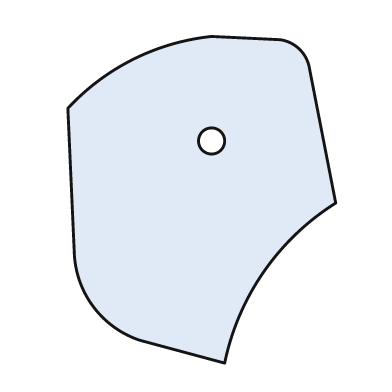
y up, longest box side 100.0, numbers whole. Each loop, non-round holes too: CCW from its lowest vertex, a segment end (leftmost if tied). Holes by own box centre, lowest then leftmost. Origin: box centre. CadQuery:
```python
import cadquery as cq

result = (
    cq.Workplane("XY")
    .moveTo(7.0, -50.0)
    .threePointArc((19.0, -22.0), (41.0, -1.0))
    .lineTo(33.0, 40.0)
    .threePointArc((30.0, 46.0), (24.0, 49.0))
    .lineTo(3.0, 50.0)
    .threePointArc((-21.0, 43.0), (-41.0, 28.0))
    .lineTo(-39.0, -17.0)
    .threePointArc((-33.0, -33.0), (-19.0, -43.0))
    .close()
    .moveTo(3.0, 18.0)
    .circle(4.0)
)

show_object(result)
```